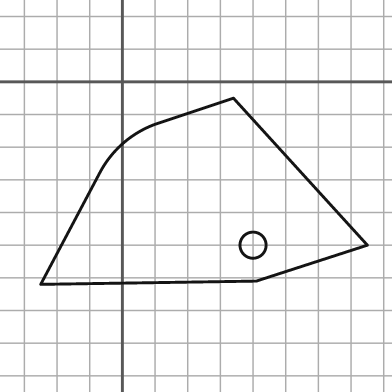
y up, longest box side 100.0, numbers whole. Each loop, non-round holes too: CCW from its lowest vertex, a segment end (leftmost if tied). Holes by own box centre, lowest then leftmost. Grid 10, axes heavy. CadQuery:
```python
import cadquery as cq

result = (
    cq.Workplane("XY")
    .moveTo(-25.0, -62.0)
    .lineTo(41.0, -61.0)
    .lineTo(75.0, -50.0)
    .lineTo(34.0, -5.0)
    .lineTo(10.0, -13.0)
    .threePointArc((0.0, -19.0), (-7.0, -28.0))
    .close()
    .moveTo(40.0, -50.0)
    .circle(4.0)
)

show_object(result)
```